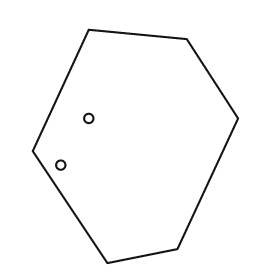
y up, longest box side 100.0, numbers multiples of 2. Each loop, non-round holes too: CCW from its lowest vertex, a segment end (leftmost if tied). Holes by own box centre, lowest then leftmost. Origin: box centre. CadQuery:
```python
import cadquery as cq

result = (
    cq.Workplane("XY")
    .moveTo(-12.0, -50.0)
    .lineTo(18.0, -44.0)
    .lineTo(44.0, 12.0)
    .lineTo(22.0, 46.0)
    .lineTo(-20.0, 50.0)
    .lineTo(-44.0, -2.0)
    .close()
    .moveTo(-32.0, -8.0)
    .circle(2.0)
    .moveTo(-20.0, 12.0)
    .circle(2.0)
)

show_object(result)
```